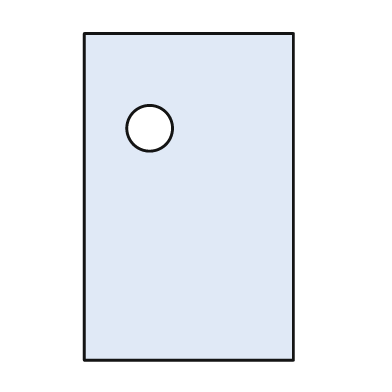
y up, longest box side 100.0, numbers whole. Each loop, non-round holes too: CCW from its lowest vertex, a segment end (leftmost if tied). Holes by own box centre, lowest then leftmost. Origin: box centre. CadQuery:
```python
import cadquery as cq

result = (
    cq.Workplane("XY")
    .moveTo(-32.0, -50.0)
    .lineTo(32.0, -50.0)
    .lineTo(32.0, 50.0)
    .lineTo(-32.0, 50.0)
    .close()
    .moveTo(-12.0, 21.0)
    .circle(7.0)
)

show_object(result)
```